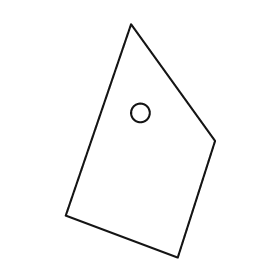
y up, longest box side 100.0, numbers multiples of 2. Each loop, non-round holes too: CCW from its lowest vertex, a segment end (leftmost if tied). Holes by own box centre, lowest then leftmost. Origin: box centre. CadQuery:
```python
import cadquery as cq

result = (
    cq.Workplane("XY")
    .moveTo(16.0, -50.0)
    .lineTo(32.0, 0.0)
    .lineTo(-4.0, 50.0)
    .lineTo(-32.0, -32.0)
    .close()
    .moveTo(0.0, 12.0)
    .circle(4.0)
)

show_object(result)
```